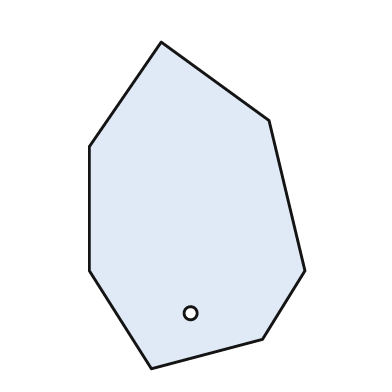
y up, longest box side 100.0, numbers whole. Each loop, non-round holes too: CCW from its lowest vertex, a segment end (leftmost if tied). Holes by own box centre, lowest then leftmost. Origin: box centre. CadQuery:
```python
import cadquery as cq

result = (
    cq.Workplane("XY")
    .moveTo(-14.0, -50.0)
    .lineTo(20.0, -41.0)
    .lineTo(33.0, -20.0)
    .lineTo(22.0, 26.0)
    .lineTo(-11.0, 50.0)
    .lineTo(-33.0, 18.0)
    .lineTo(-33.0, -20.0)
    .close()
    .moveTo(-2.0, -33.0)
    .circle(2.0)
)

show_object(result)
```